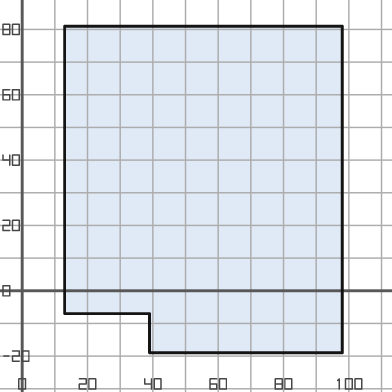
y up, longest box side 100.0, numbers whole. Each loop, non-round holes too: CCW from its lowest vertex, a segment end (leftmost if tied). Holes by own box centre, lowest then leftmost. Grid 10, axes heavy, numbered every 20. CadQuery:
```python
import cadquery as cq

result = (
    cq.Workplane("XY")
    .moveTo(39.0, -19.0)
    .lineTo(98.0, -19.0)
    .lineTo(98.0, 81.0)
    .lineTo(13.0, 81.0)
    .lineTo(13.0, -7.0)
    .lineTo(39.0, -7.0)
    .close()
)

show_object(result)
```